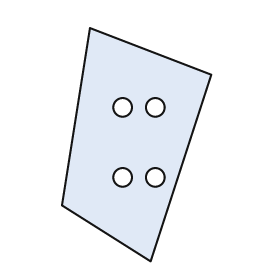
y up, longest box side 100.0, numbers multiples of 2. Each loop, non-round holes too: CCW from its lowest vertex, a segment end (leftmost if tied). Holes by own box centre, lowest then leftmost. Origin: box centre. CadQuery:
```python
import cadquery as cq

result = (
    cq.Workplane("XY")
    .moveTo(6.0, -50.0)
    .lineTo(32.0, 30.0)
    .lineTo(-20.0, 50.0)
    .lineTo(-32.0, -26.0)
    .close()
    .moveTo(-6.0, -14.0)
    .circle(4.0)
    .moveTo(8.0, -14.0)
    .circle(4.0)
    .moveTo(-6.0, 16.0)
    .circle(4.0)
    .moveTo(8.0, 16.0)
    .circle(4.0)
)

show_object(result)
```